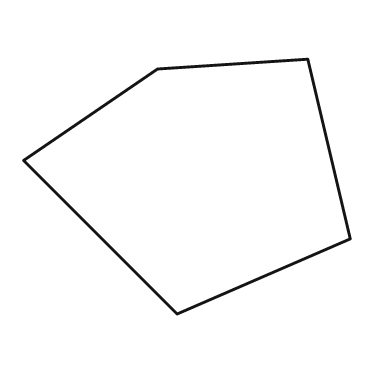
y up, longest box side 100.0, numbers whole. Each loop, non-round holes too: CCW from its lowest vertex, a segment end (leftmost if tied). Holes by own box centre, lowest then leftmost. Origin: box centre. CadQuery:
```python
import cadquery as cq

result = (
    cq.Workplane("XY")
    .moveTo(-3.0, -39.0)
    .lineTo(50.0, -16.0)
    .lineTo(37.0, 39.0)
    .lineTo(-9.0, 36.0)
    .lineTo(-50.0, 8.0)
    .close()
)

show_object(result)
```